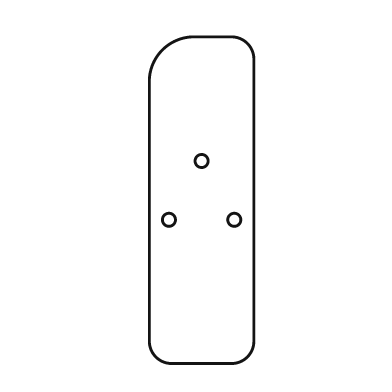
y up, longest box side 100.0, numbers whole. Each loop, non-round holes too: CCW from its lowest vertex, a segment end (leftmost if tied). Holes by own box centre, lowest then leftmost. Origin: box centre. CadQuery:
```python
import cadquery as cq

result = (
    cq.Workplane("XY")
    .moveTo(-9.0, -50.0)
    .lineTo(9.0, -50.0)
    .threePointArc((14.0, -48.0), (16.0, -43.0))
    .lineTo(16.0, 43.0)
    .threePointArc((14.0, 48.0), (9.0, 50.0))
    .lineTo(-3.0, 50.0)
    .threePointArc((-12.0, 46.0), (-16.0, 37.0))
    .lineTo(-16.0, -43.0)
    .threePointArc((-14.0, -48.0), (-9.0, -50.0))
    .close()
    .moveTo(-10.0, -6.0)
    .circle(2.0)
    .moveTo(10.0, -6.0)
    .circle(2.0)
    .moveTo(0.0, 12.0)
    .circle(2.0)
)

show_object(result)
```